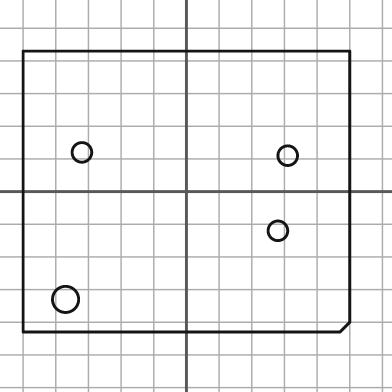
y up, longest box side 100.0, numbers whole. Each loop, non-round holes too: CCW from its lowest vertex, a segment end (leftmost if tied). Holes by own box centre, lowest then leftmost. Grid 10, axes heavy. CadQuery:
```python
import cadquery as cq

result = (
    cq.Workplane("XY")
    .moveTo(-50.0, -43.0)
    .lineTo(47.0, -43.0)
    .lineTo(50.0, -40.0)
    .lineTo(50.0, 43.0)
    .lineTo(-50.0, 43.0)
    .close()
    .moveTo(-37.0, -33.0)
    .circle(4.0)
    .moveTo(28.0, -12.0)
    .circle(3.0)
    .moveTo(31.0, 11.0)
    .circle(3.0)
    .moveTo(-32.0, 12.0)
    .circle(3.0)
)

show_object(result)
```